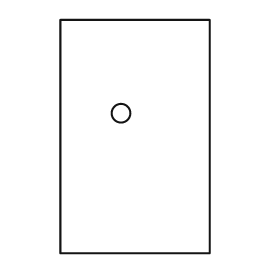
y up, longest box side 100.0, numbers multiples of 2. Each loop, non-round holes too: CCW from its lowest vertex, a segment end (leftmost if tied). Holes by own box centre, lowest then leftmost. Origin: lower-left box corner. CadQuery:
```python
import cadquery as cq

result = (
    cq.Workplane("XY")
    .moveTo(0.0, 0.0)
    .lineTo(64.0, 0.0)
    .lineTo(64.0, 100.0)
    .lineTo(0.0, 100.0)
    .close()
    .moveTo(26.0, 60.0)
    .circle(4.0)
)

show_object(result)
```